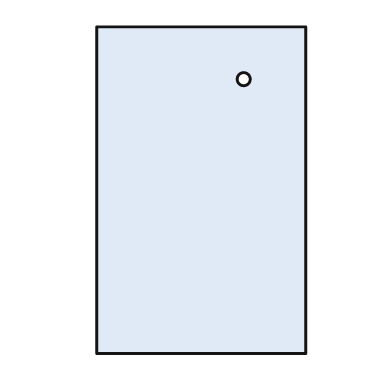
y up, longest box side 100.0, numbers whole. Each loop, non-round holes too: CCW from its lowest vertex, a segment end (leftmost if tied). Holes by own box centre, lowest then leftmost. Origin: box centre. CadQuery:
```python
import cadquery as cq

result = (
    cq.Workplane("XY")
    .moveTo(-32.0, -50.0)
    .lineTo(32.0, -50.0)
    .lineTo(32.0, 50.0)
    .lineTo(-32.0, 50.0)
    .close()
    .moveTo(13.0, 34.0)
    .circle(2.0)
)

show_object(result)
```